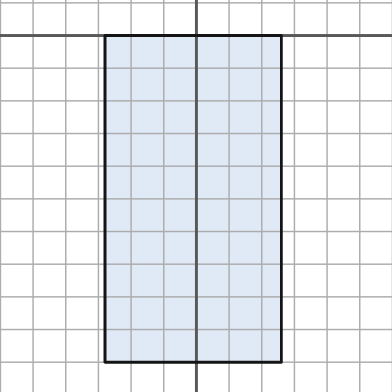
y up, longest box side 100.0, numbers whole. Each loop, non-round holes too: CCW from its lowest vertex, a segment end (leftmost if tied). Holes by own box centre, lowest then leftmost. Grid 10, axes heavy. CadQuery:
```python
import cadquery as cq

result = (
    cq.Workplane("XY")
    .moveTo(-28.0, -100.0)
    .lineTo(26.0, -100.0)
    .lineTo(26.0, 0.0)
    .lineTo(-28.0, 0.0)
    .close()
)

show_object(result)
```